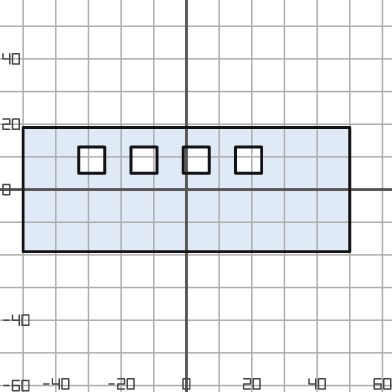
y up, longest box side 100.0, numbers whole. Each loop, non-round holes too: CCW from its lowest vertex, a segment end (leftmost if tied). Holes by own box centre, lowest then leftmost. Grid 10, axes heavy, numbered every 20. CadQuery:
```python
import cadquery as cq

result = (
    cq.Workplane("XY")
    .moveTo(-50.0, -19.0)
    .lineTo(50.0, -19.0)
    .lineTo(50.0, 19.0)
    .lineTo(-50.0, 19.0)
    .close()
    .moveTo(-33.0, 5.0)
    .lineTo(-25.0, 5.0)
    .lineTo(-25.0, 13.0)
    .lineTo(-33.0, 13.0)
    .close()
    .moveTo(-17.0, 5.0)
    .lineTo(-9.0, 5.0)
    .lineTo(-9.0, 13.0)
    .lineTo(-17.0, 13.0)
    .close()
    .moveTo(-1.0, 5.0)
    .lineTo(7.0, 5.0)
    .lineTo(7.0, 13.0)
    .lineTo(-1.0, 13.0)
    .close()
    .moveTo(15.0, 5.0)
    .lineTo(23.0, 5.0)
    .lineTo(23.0, 13.0)
    .lineTo(15.0, 13.0)
    .close()
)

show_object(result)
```